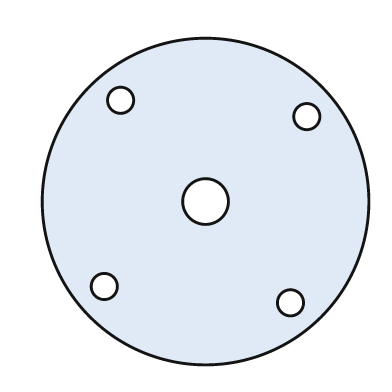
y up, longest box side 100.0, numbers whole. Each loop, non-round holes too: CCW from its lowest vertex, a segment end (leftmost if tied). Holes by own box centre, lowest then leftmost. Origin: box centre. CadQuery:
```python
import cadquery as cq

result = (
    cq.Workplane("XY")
    .moveTo(0.0, 0.0)
    .circle(50.0)
    .moveTo(26.0, -31.0)
    .circle(4.0)
    .moveTo(-31.0, -26.0)
    .circle(4.0)
    .moveTo(0.0, 0.0)
    .circle(7.0)
    .moveTo(31.0, 26.0)
    .circle(4.0)
    .moveTo(-26.0, 31.0)
    .circle(4.0)
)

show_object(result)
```